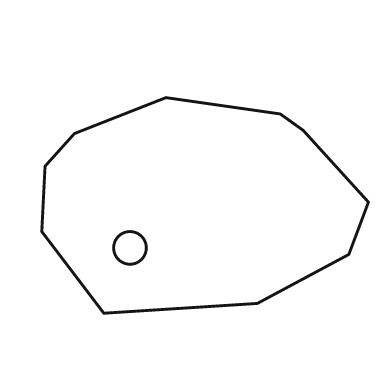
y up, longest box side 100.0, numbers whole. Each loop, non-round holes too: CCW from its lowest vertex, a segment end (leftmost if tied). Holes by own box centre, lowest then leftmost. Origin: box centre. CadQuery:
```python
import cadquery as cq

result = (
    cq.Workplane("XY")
    .moveTo(-31.0, -33.0)
    .lineTo(16.0, -30.0)
    .lineTo(44.0, -15.0)
    .lineTo(50.0, 1.0)
    .lineTo(30.0, 23.0)
    .lineTo(23.0, 28.0)
    .lineTo(-12.0, 33.0)
    .lineTo(-40.0, 22.0)
    .lineTo(-49.0, 12.0)
    .lineTo(-50.0, -8.0)
    .close()
    .moveTo(-23.0, -13.0)
    .circle(5.0)
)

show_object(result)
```